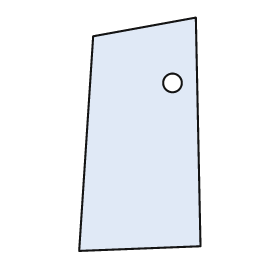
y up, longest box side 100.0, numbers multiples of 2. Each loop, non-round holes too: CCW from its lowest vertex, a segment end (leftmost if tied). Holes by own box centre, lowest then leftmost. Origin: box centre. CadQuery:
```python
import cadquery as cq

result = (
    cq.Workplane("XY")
    .moveTo(-26.0, -50.0)
    .lineTo(26.0, -48.0)
    .lineTo(24.0, 50.0)
    .lineTo(-20.0, 42.0)
    .close()
    .moveTo(14.0, 22.0)
    .circle(4.0)
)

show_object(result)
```